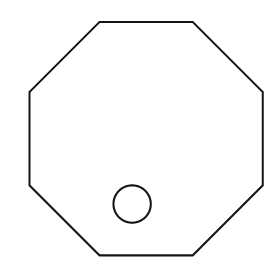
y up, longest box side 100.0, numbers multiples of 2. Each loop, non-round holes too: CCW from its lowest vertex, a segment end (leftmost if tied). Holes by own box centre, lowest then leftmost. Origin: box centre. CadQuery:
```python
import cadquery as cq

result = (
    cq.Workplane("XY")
    .moveTo(-20.0, -50.0)
    .lineTo(20.0, -50.0)
    .lineTo(50.0, -20.0)
    .lineTo(50.0, 20.0)
    .lineTo(20.0, 50.0)
    .lineTo(-20.0, 50.0)
    .lineTo(-50.0, 20.0)
    .lineTo(-50.0, -20.0)
    .close()
    .moveTo(-6.0, -28.0)
    .circle(8.0)
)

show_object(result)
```